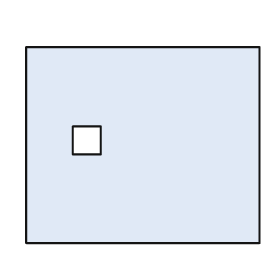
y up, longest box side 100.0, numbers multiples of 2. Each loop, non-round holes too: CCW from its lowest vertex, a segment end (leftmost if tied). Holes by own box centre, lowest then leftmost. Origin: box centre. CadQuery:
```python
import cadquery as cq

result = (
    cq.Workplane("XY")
    .moveTo(-50.0, -42.0)
    .lineTo(50.0, -42.0)
    .lineTo(50.0, 42.0)
    .lineTo(-50.0, 42.0)
    .close()
    .moveTo(-30.0, -4.0)
    .lineTo(-18.0, -4.0)
    .lineTo(-18.0, 8.0)
    .lineTo(-30.0, 8.0)
    .close()
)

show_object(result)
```